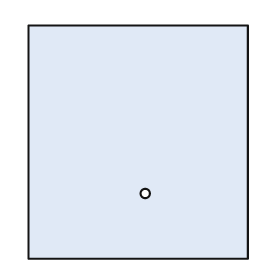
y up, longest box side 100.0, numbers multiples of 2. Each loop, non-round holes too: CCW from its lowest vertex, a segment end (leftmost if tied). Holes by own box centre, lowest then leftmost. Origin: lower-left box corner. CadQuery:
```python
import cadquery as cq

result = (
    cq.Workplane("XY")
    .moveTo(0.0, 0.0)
    .lineTo(94.0, 0.0)
    .lineTo(94.0, 100.0)
    .lineTo(0.0, 100.0)
    .close()
    .moveTo(50.0, 28.0)
    .circle(2.0)
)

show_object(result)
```